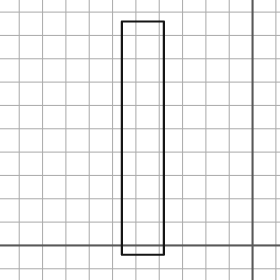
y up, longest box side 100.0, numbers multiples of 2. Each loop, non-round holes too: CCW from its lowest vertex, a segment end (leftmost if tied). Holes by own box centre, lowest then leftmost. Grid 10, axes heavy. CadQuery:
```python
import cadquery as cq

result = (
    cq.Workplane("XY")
    .moveTo(-56.0, -4.0)
    .lineTo(-38.0, -4.0)
    .lineTo(-38.0, 96.0)
    .lineTo(-56.0, 96.0)
    .close()
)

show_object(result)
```